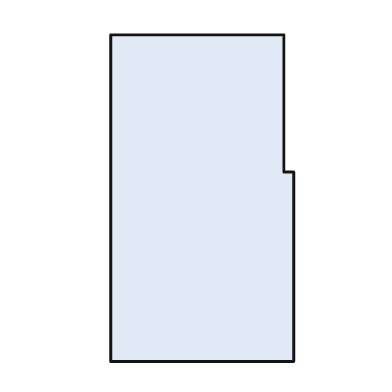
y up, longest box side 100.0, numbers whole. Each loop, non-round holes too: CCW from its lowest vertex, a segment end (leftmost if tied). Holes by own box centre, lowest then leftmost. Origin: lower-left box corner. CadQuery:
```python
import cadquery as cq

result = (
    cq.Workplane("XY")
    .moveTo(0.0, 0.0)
    .lineTo(56.0, 0.0)
    .lineTo(56.0, 58.0)
    .lineTo(53.0, 58.0)
    .lineTo(53.0, 100.0)
    .lineTo(0.0, 100.0)
    .close()
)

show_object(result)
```